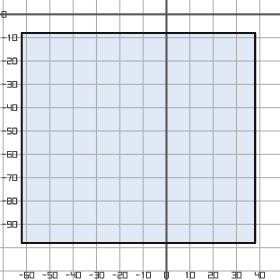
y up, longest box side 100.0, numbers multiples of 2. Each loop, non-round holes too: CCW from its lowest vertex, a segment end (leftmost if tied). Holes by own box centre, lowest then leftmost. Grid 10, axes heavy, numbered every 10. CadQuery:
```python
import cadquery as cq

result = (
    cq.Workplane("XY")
    .moveTo(-62.0, -98.0)
    .lineTo(38.0, -98.0)
    .lineTo(38.0, -8.0)
    .lineTo(-62.0, -8.0)
    .close()
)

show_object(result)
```